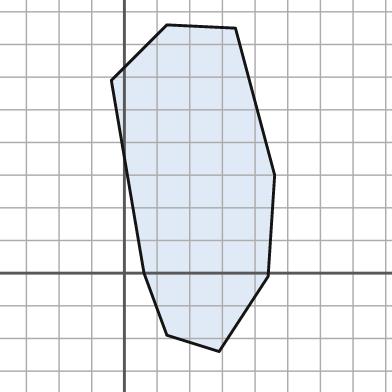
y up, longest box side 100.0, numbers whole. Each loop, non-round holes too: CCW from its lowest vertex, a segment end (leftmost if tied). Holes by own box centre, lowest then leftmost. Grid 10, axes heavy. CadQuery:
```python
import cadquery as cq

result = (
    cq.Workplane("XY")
    .moveTo(29.0, -24.0)
    .lineTo(44.0, -1.0)
    .lineTo(46.0, 30.0)
    .lineTo(34.0, 75.0)
    .lineTo(13.0, 76.0)
    .lineTo(-4.0, 59.0)
    .lineTo(6.0, 0.0)
    .lineTo(13.0, -19.0)
    .close()
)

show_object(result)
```